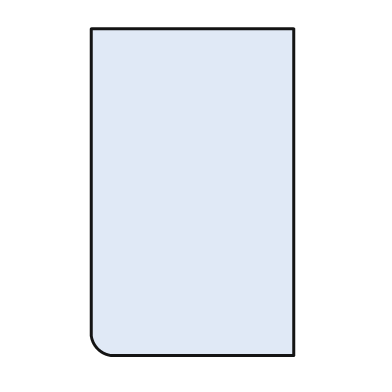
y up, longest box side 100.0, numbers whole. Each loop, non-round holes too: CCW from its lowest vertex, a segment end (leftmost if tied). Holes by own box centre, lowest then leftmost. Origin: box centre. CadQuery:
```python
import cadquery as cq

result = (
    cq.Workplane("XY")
    .moveTo(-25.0, -50.0)
    .lineTo(31.0, -50.0)
    .lineTo(31.0, 50.0)
    .lineTo(-31.0, 50.0)
    .lineTo(-31.0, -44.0)
    .threePointArc((-29.0, -48.0), (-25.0, -50.0))
    .close()
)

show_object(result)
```